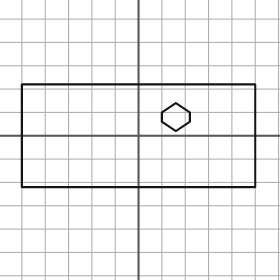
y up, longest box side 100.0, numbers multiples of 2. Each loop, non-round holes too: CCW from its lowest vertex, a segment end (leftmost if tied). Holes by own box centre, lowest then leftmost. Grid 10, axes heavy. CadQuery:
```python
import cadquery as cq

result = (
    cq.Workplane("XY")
    .moveTo(-50.0, -22.0)
    .lineTo(50.0, -22.0)
    .lineTo(50.0, 22.0)
    .lineTo(-50.0, 22.0)
    .close()
    .moveTo(16.0, 2.0)
    .lineTo(22.0, 6.0)
    .lineTo(22.0, 10.0)
    .lineTo(16.0, 14.0)
    .lineTo(10.0, 10.0)
    .lineTo(10.0, 6.0)
    .close()
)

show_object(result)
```